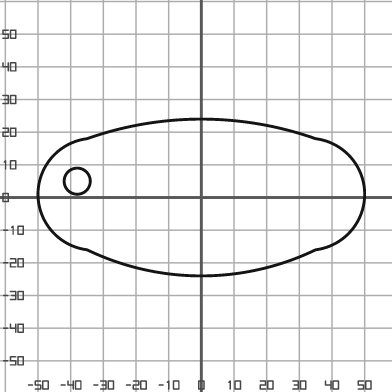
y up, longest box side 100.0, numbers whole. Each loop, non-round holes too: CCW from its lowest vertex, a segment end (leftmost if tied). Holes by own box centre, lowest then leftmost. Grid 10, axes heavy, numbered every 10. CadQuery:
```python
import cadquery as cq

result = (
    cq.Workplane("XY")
    .moveTo(-35.0, -16.0)
    .threePointArc((0.0, -24.0), (35.0, -16.0))
    .threePointArc((50.0, 1.0), (35.0, 18.0))
    .threePointArc((0.0, 24.0), (-35.0, 18.0))
    .threePointArc((-50.0, 1.0), (-35.0, -16.0))
    .close()
    .moveTo(-38.0, 5.0)
    .circle(4.0)
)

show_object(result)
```